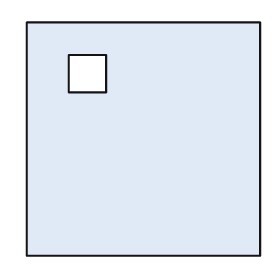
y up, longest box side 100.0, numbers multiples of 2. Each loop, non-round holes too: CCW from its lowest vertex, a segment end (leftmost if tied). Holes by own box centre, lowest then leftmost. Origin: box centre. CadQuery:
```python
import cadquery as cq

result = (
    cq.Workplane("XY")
    .moveTo(-50.0, -50.0)
    .lineTo(50.0, -50.0)
    .lineTo(50.0, 50.0)
    .lineTo(-50.0, 50.0)
    .close()
    .moveTo(-32.0, 20.0)
    .lineTo(-16.0, 20.0)
    .lineTo(-16.0, 36.0)
    .lineTo(-32.0, 36.0)
    .close()
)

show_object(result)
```